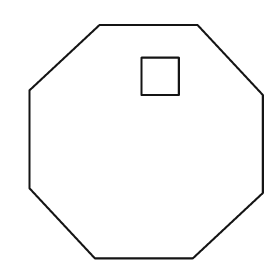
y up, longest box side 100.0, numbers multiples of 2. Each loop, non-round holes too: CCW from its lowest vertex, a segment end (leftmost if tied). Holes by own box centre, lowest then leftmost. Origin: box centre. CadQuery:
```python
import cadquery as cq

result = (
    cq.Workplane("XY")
    .moveTo(-22.0, -50.0)
    .lineTo(20.0, -50.0)
    .lineTo(50.0, -22.0)
    .lineTo(50.0, 20.0)
    .lineTo(22.0, 50.0)
    .lineTo(-20.0, 50.0)
    .lineTo(-50.0, 22.0)
    .lineTo(-50.0, -20.0)
    .close()
    .moveTo(-2.0, 20.0)
    .lineTo(14.0, 20.0)
    .lineTo(14.0, 36.0)
    .lineTo(-2.0, 36.0)
    .close()
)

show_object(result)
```